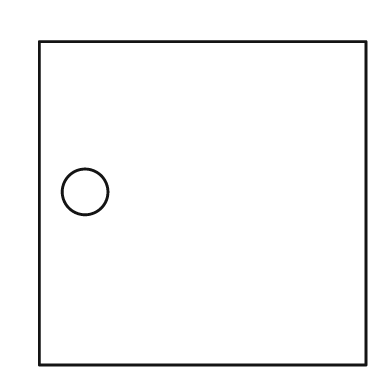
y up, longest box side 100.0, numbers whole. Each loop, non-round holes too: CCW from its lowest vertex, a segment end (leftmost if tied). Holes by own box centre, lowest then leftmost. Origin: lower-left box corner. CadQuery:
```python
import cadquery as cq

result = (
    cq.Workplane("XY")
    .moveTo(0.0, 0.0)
    .lineTo(100.0, 0.0)
    .lineTo(100.0, 99.0)
    .lineTo(0.0, 99.0)
    .close()
    .moveTo(14.0, 53.0)
    .circle(7.0)
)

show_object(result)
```